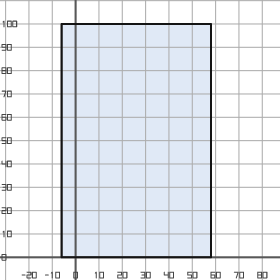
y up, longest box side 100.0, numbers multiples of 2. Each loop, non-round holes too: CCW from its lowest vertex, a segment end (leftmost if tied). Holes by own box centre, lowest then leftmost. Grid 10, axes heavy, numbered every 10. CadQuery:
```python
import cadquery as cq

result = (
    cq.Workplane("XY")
    .moveTo(-6.0, 0.0)
    .lineTo(58.0, 0.0)
    .lineTo(58.0, 100.0)
    .lineTo(-6.0, 100.0)
    .close()
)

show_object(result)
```